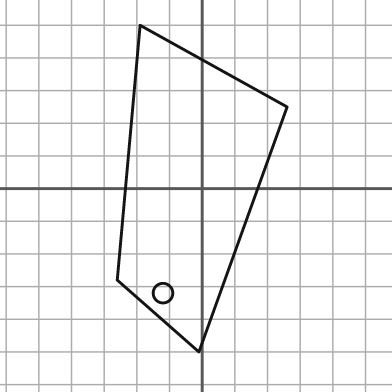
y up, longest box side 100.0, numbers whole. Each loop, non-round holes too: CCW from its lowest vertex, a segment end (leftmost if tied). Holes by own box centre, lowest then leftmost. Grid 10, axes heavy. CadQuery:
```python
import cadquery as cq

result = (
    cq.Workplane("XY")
    .moveTo(-1.0, -50.0)
    .lineTo(26.0, 25.0)
    .lineTo(-19.0, 50.0)
    .lineTo(-26.0, -28.0)
    .close()
    .moveTo(-12.0, -32.0)
    .circle(3.0)
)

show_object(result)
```